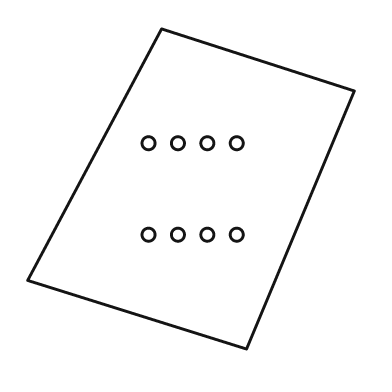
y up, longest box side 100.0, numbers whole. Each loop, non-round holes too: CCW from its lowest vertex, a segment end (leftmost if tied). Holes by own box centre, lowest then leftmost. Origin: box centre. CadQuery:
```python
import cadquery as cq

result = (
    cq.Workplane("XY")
    .moveTo(17.0, -49.0)
    .lineTo(50.0, 30.0)
    .lineTo(-9.0, 49.0)
    .lineTo(-50.0, -28.0)
    .close()
    .moveTo(-13.0, -14.0)
    .circle(2.0)
    .moveTo(-4.0, -14.0)
    .circle(2.0)
    .moveTo(5.0, -14.0)
    .circle(2.0)
    .moveTo(14.0, -14.0)
    .circle(2.0)
    .moveTo(-13.0, 14.0)
    .circle(2.0)
    .moveTo(-4.0, 14.0)
    .circle(2.0)
    .moveTo(5.0, 14.0)
    .circle(2.0)
    .moveTo(14.0, 14.0)
    .circle(2.0)
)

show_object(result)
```